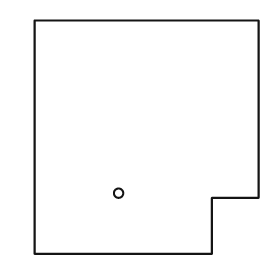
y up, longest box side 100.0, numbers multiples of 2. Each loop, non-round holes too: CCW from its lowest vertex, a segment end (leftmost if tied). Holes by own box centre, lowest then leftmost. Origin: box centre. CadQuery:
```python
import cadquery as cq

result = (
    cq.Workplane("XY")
    .moveTo(-48.0, -50.0)
    .lineTo(28.0, -50.0)
    .lineTo(28.0, -26.0)
    .lineTo(48.0, -26.0)
    .lineTo(48.0, 50.0)
    .lineTo(-48.0, 50.0)
    .close()
    .moveTo(-12.0, -24.0)
    .circle(2.0)
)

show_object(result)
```